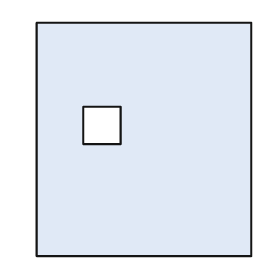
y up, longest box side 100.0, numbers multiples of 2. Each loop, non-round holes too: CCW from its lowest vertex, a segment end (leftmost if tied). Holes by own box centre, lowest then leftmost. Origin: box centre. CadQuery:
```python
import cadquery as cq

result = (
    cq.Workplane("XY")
    .moveTo(-46.0, -50.0)
    .lineTo(46.0, -50.0)
    .lineTo(46.0, 50.0)
    .lineTo(-46.0, 50.0)
    .close()
    .moveTo(-26.0, -2.0)
    .lineTo(-10.0, -2.0)
    .lineTo(-10.0, 14.0)
    .lineTo(-26.0, 14.0)
    .close()
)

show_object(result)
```